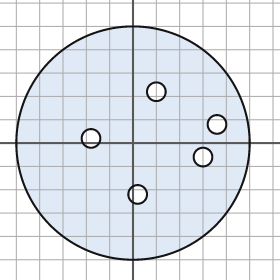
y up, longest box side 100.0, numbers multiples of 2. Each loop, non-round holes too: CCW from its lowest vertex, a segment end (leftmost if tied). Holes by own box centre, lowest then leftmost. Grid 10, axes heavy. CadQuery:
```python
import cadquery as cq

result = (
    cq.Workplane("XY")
    .moveTo(0.0, 0.0)
    .circle(50.0)
    .moveTo(2.0, -22.0)
    .circle(4.0)
    .moveTo(30.0, -6.0)
    .circle(4.0)
    .moveTo(-18.0, 2.0)
    .circle(4.0)
    .moveTo(36.0, 8.0)
    .circle(4.0)
    .moveTo(10.0, 22.0)
    .circle(4.0)
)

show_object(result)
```